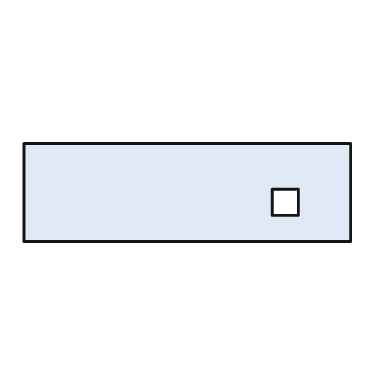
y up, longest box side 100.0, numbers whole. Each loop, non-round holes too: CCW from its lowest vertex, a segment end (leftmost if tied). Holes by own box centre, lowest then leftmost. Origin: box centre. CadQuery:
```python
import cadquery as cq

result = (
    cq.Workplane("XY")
    .moveTo(-50.0, -15.0)
    .lineTo(50.0, -15.0)
    .lineTo(50.0, 15.0)
    .lineTo(-50.0, 15.0)
    .close()
    .moveTo(26.0, -7.0)
    .lineTo(34.0, -7.0)
    .lineTo(34.0, 1.0)
    .lineTo(26.0, 1.0)
    .close()
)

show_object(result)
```